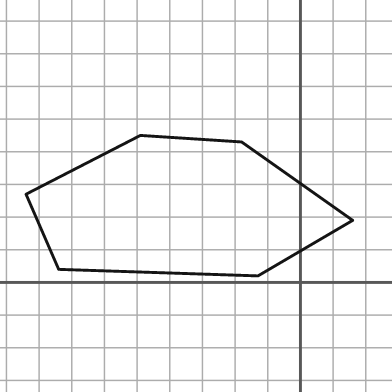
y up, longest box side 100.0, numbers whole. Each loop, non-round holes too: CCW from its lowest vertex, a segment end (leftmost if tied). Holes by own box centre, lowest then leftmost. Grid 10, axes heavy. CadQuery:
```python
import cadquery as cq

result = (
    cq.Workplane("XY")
    .moveTo(-13.0, 2.0)
    .lineTo(16.0, 19.0)
    .lineTo(-18.0, 43.0)
    .lineTo(-49.0, 45.0)
    .lineTo(-84.0, 27.0)
    .lineTo(-74.0, 4.0)
    .close()
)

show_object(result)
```